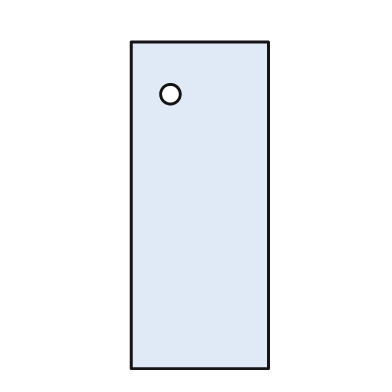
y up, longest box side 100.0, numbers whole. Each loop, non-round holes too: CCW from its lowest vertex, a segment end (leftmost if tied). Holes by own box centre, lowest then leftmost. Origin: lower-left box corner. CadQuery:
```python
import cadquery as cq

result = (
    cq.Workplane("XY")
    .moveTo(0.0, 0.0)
    .lineTo(42.0, 0.0)
    .lineTo(42.0, 100.0)
    .lineTo(0.0, 100.0)
    .close()
    .moveTo(12.0, 84.0)
    .circle(3.0)
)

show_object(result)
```